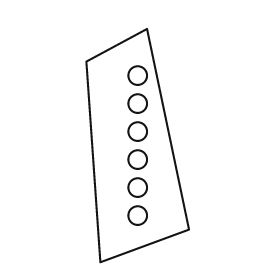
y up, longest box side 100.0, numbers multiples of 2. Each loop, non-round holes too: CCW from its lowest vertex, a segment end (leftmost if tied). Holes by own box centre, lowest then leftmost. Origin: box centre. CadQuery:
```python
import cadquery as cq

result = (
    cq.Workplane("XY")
    .moveTo(-16.0, -50.0)
    .lineTo(22.0, -36.0)
    .lineTo(4.0, 50.0)
    .lineTo(-22.0, 36.0)
    .close()
    .moveTo(0.0, -30.0)
    .circle(4.0)
    .moveTo(0.0, -18.0)
    .circle(4.0)
    .moveTo(0.0, -6.0)
    .circle(4.0)
    .moveTo(0.0, 6.0)
    .circle(4.0)
    .moveTo(0.0, 18.0)
    .circle(4.0)
    .moveTo(0.0, 30.0)
    .circle(4.0)
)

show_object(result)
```